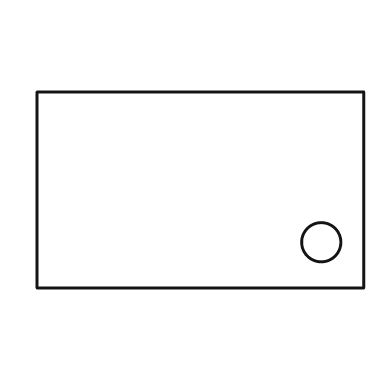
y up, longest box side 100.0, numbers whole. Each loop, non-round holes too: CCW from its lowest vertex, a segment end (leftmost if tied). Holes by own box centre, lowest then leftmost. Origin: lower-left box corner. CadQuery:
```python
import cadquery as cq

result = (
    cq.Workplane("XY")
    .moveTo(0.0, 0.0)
    .lineTo(100.0, 0.0)
    .lineTo(100.0, 60.0)
    .lineTo(0.0, 60.0)
    .close()
    .moveTo(87.0, 14.0)
    .circle(6.0)
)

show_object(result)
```